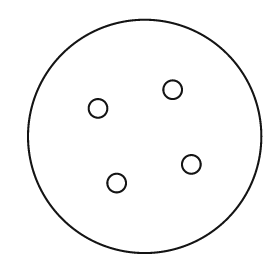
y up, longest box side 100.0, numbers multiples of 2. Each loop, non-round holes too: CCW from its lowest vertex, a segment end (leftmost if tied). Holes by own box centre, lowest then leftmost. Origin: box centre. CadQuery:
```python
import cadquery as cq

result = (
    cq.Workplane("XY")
    .moveTo(0.0, 0.0)
    .circle(50.0)
    .moveTo(-12.0, -20.0)
    .circle(4.0)
    .moveTo(20.0, -12.0)
    .circle(4.0)
    .moveTo(-20.0, 12.0)
    .circle(4.0)
    .moveTo(12.0, 20.0)
    .circle(4.0)
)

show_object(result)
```